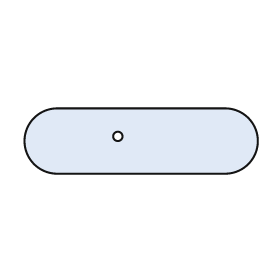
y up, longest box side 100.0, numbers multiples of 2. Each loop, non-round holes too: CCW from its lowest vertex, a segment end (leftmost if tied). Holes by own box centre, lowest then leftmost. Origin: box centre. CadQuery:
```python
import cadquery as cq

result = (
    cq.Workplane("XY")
    .moveTo(-36.0, -14.0)
    .lineTo(36.0, -14.0)
    .threePointArc((50.0, 0.0), (36.0, 14.0))
    .lineTo(-36.0, 14.0)
    .threePointArc((-50.0, 0.0), (-36.0, -14.0))
    .close()
    .moveTo(-10.0, 2.0)
    .circle(2.0)
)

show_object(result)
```